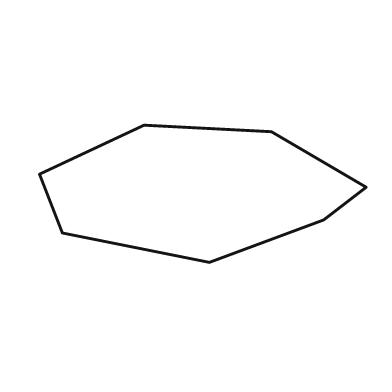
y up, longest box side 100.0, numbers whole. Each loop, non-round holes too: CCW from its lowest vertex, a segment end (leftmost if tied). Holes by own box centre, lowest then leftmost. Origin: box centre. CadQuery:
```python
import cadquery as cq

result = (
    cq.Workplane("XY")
    .moveTo(2.0, -21.0)
    .lineTo(37.0, -8.0)
    .lineTo(50.0, 2.0)
    .lineTo(21.0, 19.0)
    .lineTo(-18.0, 21.0)
    .lineTo(-50.0, 6.0)
    .lineTo(-43.0, -12.0)
    .close()
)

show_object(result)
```